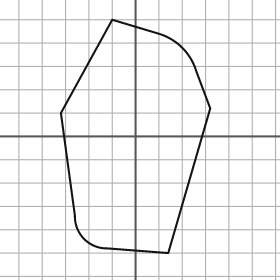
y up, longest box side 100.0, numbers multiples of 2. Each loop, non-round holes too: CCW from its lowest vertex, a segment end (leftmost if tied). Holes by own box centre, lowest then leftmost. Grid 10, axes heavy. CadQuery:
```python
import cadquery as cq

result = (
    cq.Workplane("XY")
    .moveTo(14.0, -50.0)
    .lineTo(32.0, 12.0)
    .lineTo(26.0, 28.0)
    .threePointArc((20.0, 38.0), (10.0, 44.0))
    .lineTo(-10.0, 50.0)
    .lineTo(-32.0, 10.0)
    .lineTo(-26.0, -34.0)
    .threePointArc((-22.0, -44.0), (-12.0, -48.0))
    .close()
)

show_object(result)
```